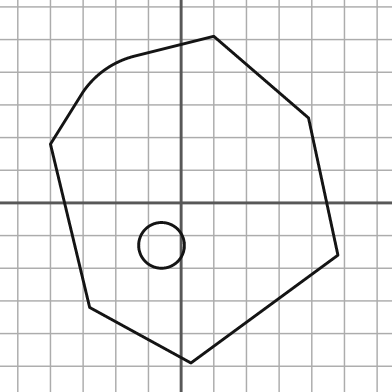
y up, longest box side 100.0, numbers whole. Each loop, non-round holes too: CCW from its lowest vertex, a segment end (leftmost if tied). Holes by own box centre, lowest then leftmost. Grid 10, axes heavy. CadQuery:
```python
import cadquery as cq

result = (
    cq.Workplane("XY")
    .moveTo(3.0, -49.0)
    .lineTo(48.0, -16.0)
    .lineTo(39.0, 26.0)
    .lineTo(10.0, 51.0)
    .lineTo(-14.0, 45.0)
    .threePointArc((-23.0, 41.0), (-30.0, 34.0))
    .lineTo(-40.0, 18.0)
    .lineTo(-28.0, -32.0)
    .close()
    .moveTo(-6.0, -13.0)
    .circle(7.0)
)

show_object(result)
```